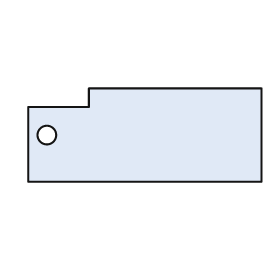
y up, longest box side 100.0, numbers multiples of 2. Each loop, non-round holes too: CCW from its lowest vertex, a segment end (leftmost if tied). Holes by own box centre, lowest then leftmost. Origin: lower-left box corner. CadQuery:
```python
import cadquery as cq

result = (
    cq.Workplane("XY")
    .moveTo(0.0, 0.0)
    .lineTo(100.0, 0.0)
    .lineTo(100.0, 40.0)
    .lineTo(26.0, 40.0)
    .lineTo(26.0, 32.0)
    .lineTo(0.0, 32.0)
    .close()
    .moveTo(8.0, 20.0)
    .circle(4.0)
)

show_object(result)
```